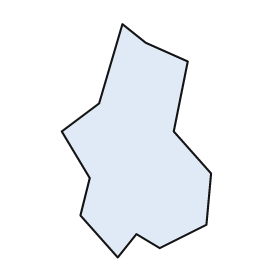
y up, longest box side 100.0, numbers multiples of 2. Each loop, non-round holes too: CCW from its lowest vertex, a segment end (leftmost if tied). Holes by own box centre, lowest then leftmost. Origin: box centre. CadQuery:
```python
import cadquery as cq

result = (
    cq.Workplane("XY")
    .moveTo(-8.0, -50.0)
    .lineTo(0.0, -40.0)
    .lineTo(10.0, -46.0)
    .lineTo(30.0, -36.0)
    .lineTo(32.0, -14.0)
    .lineTo(16.0, 4.0)
    .lineTo(22.0, 34.0)
    .lineTo(4.0, 42.0)
    .lineTo(-6.0, 50.0)
    .lineTo(-16.0, 16.0)
    .lineTo(-32.0, 4.0)
    .lineTo(-20.0, -16.0)
    .lineTo(-24.0, -32.0)
    .close()
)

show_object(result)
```